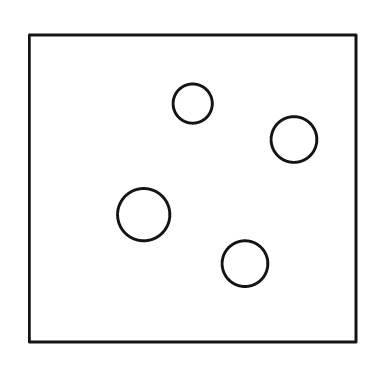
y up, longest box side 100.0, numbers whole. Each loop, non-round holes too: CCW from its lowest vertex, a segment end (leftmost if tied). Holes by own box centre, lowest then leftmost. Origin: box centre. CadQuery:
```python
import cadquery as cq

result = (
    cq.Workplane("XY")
    .moveTo(-50.0, -47.0)
    .lineTo(50.0, -47.0)
    .lineTo(50.0, 47.0)
    .lineTo(-50.0, 47.0)
    .close()
    .moveTo(16.0, -23.0)
    .circle(7.0)
    .moveTo(-15.0, -8.0)
    .circle(8.0)
    .moveTo(31.0, 15.0)
    .circle(7.0)
    .moveTo(0.0, 26.0)
    .circle(6.0)
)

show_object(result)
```